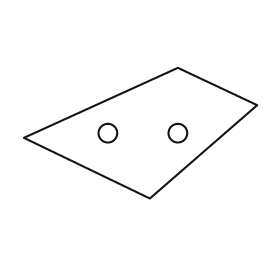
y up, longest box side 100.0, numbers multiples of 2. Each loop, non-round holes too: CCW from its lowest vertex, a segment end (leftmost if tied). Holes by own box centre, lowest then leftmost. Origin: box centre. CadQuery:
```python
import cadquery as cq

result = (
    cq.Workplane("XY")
    .moveTo(4.0, -28.0)
    .lineTo(50.0, 12.0)
    .lineTo(16.0, 28.0)
    .lineTo(-50.0, -2.0)
    .close()
    .moveTo(-14.0, 0.0)
    .circle(4.0)
    .moveTo(16.0, 0.0)
    .circle(4.0)
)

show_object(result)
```